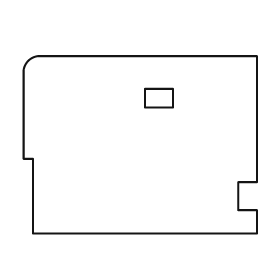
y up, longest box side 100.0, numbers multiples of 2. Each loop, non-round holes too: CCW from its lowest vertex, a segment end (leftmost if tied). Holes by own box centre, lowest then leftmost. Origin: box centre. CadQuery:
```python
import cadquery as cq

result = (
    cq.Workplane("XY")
    .moveTo(-46.0, -38.0)
    .lineTo(50.0, -38.0)
    .lineTo(50.0, -28.0)
    .lineTo(42.0, -28.0)
    .lineTo(42.0, -16.0)
    .lineTo(50.0, -16.0)
    .lineTo(50.0, 38.0)
    .lineTo(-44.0, 38.0)
    .threePointArc((-48.0, 36.0), (-50.0, 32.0))
    .lineTo(-50.0, -6.0)
    .lineTo(-46.0, -6.0)
    .close()
    .moveTo(2.0, 16.0)
    .lineTo(14.0, 16.0)
    .lineTo(14.0, 24.0)
    .lineTo(2.0, 24.0)
    .close()
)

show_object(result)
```